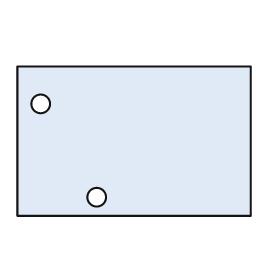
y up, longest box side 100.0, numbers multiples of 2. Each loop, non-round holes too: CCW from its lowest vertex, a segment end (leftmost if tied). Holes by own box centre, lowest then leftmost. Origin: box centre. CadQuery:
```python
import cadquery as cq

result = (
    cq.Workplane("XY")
    .moveTo(-50.0, -32.0)
    .lineTo(50.0, -32.0)
    .lineTo(50.0, 32.0)
    .lineTo(-50.0, 32.0)
    .close()
    .moveTo(-16.0, -24.0)
    .circle(4.0)
    .moveTo(-40.0, 16.0)
    .circle(4.0)
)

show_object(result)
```